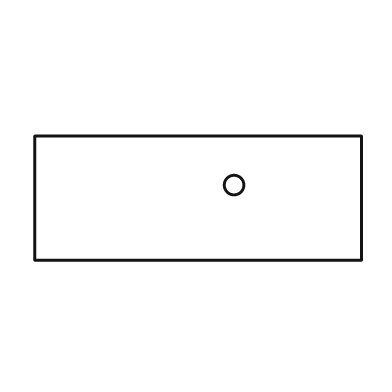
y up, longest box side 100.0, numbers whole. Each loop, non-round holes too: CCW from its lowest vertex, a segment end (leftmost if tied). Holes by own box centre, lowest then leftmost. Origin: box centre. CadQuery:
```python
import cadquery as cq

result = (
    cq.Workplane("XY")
    .moveTo(-50.0, -19.0)
    .lineTo(50.0, -19.0)
    .lineTo(50.0, 19.0)
    .lineTo(-50.0, 19.0)
    .close()
    .moveTo(11.0, 4.0)
    .circle(3.0)
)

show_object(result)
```